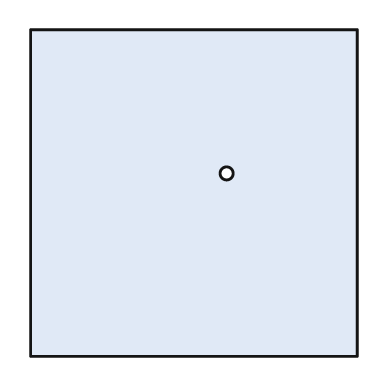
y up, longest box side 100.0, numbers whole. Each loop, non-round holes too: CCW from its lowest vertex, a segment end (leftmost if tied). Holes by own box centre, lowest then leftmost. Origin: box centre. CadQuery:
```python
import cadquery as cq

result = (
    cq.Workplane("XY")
    .moveTo(-50.0, -50.0)
    .lineTo(50.0, -50.0)
    .lineTo(50.0, 50.0)
    .lineTo(-50.0, 50.0)
    .close()
    .moveTo(10.0, 6.0)
    .circle(2.0)
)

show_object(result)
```